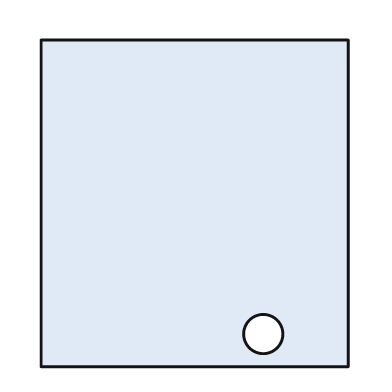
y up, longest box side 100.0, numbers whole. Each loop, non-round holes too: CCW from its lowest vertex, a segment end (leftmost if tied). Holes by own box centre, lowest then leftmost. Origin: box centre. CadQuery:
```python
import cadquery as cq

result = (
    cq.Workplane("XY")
    .moveTo(-47.0, -50.0)
    .lineTo(47.0, -50.0)
    .lineTo(47.0, 50.0)
    .lineTo(-47.0, 50.0)
    .close()
    .moveTo(21.0, -40.0)
    .circle(6.0)
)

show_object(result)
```